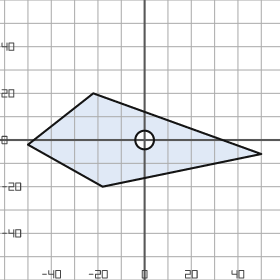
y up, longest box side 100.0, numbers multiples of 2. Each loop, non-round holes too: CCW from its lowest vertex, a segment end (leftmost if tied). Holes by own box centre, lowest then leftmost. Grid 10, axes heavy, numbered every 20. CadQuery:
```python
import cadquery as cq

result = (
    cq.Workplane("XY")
    .moveTo(-18.0, -20.0)
    .lineTo(50.0, -6.0)
    .lineTo(-22.0, 20.0)
    .lineTo(-50.0, -2.0)
    .close()
    .moveTo(0.0, 0.0)
    .circle(4.0)
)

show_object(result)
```